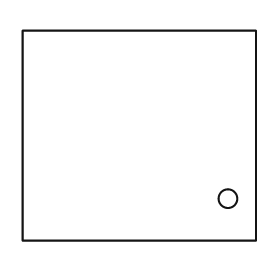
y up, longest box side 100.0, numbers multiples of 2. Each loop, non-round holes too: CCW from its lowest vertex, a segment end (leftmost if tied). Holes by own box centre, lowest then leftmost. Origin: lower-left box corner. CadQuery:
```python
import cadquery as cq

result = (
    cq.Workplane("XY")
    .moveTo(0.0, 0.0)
    .lineTo(100.0, 0.0)
    .lineTo(100.0, 90.0)
    .lineTo(0.0, 90.0)
    .close()
    .moveTo(88.0, 18.0)
    .circle(4.0)
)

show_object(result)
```